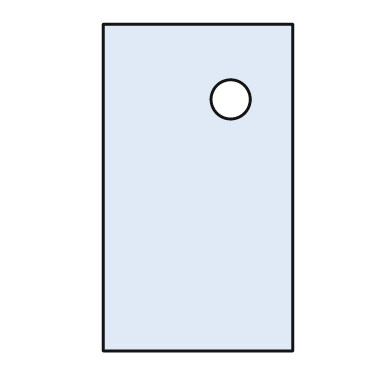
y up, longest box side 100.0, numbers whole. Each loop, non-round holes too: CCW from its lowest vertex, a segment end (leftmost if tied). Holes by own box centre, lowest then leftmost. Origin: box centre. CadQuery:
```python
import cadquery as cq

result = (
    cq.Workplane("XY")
    .moveTo(-29.0, -50.0)
    .lineTo(29.0, -50.0)
    .lineTo(29.0, 50.0)
    .lineTo(-29.0, 50.0)
    .close()
    .moveTo(10.0, 27.0)
    .circle(6.0)
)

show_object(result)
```